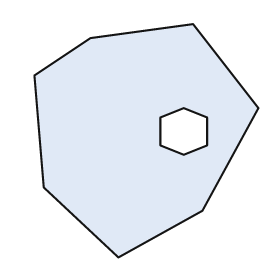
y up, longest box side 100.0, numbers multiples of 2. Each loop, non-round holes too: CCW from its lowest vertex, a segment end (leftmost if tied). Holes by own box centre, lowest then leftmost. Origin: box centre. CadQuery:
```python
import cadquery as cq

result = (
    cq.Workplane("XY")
    .moveTo(-12.0, -50.0)
    .lineTo(24.0, -30.0)
    .lineTo(48.0, 14.0)
    .lineTo(20.0, 50.0)
    .lineTo(-24.0, 44.0)
    .lineTo(-48.0, 28.0)
    .lineTo(-44.0, -20.0)
    .close()
    .moveTo(16.0, -6.0)
    .lineTo(26.0, -2.0)
    .lineTo(26.0, 10.0)
    .lineTo(16.0, 14.0)
    .lineTo(6.0, 10.0)
    .lineTo(6.0, -2.0)
    .close()
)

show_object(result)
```